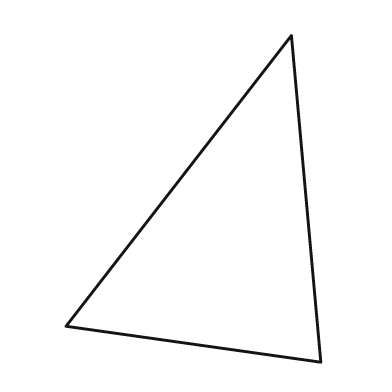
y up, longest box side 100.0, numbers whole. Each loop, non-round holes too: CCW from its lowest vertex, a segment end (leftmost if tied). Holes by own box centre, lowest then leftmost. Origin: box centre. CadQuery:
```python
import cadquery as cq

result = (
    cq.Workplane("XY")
    .moveTo(39.0, -50.0)
    .lineTo(30.0, 50.0)
    .lineTo(-39.0, -39.0)
    .close()
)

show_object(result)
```